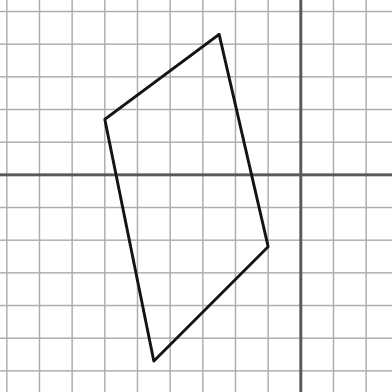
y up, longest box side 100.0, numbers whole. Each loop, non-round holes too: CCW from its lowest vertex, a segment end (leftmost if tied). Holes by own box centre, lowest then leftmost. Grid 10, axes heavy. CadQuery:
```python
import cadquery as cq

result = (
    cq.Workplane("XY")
    .moveTo(-45.0, -57.0)
    .lineTo(-10.0, -22.0)
    .lineTo(-25.0, 43.0)
    .lineTo(-60.0, 17.0)
    .close()
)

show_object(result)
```